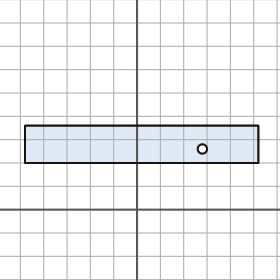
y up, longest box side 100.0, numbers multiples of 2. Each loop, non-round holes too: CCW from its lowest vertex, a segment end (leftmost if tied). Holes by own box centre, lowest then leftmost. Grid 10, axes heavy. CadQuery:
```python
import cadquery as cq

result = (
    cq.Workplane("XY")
    .moveTo(-48.0, 20.0)
    .lineTo(52.0, 20.0)
    .lineTo(52.0, 36.0)
    .lineTo(-48.0, 36.0)
    .close()
    .moveTo(28.0, 26.0)
    .circle(2.0)
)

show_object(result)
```